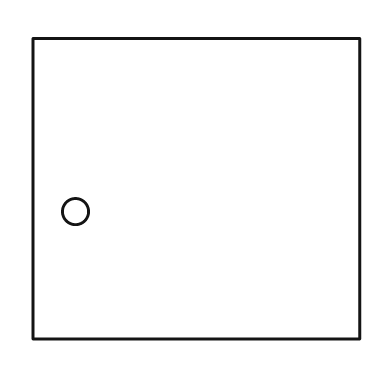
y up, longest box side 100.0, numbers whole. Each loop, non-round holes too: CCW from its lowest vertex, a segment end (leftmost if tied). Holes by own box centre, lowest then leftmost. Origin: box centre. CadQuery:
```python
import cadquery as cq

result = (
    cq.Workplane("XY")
    .moveTo(-50.0, -46.0)
    .lineTo(50.0, -46.0)
    .lineTo(50.0, 46.0)
    .lineTo(-50.0, 46.0)
    .close()
    .moveTo(-37.0, -7.0)
    .circle(4.0)
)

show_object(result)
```